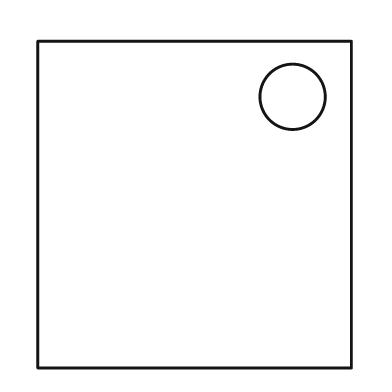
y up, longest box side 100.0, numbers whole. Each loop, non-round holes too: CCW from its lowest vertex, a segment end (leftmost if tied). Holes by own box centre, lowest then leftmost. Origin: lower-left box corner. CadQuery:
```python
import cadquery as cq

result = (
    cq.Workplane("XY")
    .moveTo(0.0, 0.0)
    .lineTo(96.0, 0.0)
    .lineTo(96.0, 100.0)
    .lineTo(0.0, 100.0)
    .close()
    .moveTo(78.0, 83.0)
    .circle(10.0)
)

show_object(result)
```